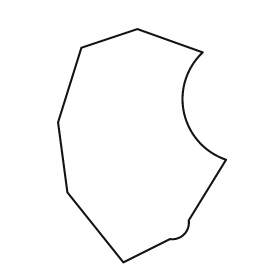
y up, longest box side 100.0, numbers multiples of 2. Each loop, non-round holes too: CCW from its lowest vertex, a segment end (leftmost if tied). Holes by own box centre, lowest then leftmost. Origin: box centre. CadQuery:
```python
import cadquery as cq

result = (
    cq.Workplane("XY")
    .moveTo(-8.0, -50.0)
    .lineTo(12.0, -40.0)
    .threePointArc((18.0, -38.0), (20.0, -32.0))
    .lineTo(36.0, -6.0)
    .threePointArc((18.0, 14.0), (26.0, 40.0))
    .lineTo(-2.0, 50.0)
    .lineTo(-26.0, 42.0)
    .lineTo(-36.0, 10.0)
    .lineTo(-32.0, -20.0)
    .close()
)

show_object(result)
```